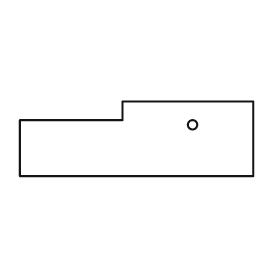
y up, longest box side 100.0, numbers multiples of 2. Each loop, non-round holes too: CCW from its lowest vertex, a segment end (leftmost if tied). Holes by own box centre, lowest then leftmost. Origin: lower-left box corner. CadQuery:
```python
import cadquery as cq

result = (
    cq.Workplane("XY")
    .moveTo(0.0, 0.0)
    .lineTo(100.0, 0.0)
    .lineTo(100.0, 32.0)
    .lineTo(44.0, 32.0)
    .lineTo(44.0, 24.0)
    .lineTo(0.0, 24.0)
    .close()
    .moveTo(74.0, 22.0)
    .circle(2.0)
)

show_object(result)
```